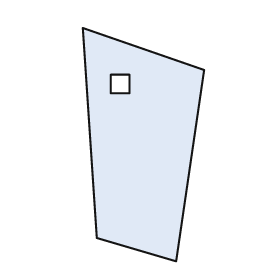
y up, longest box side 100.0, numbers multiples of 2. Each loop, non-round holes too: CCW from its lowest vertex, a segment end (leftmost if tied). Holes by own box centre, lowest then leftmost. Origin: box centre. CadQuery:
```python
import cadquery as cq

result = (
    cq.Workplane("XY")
    .moveTo(14.0, -50.0)
    .lineTo(26.0, 32.0)
    .lineTo(-26.0, 50.0)
    .lineTo(-20.0, -40.0)
    .close()
    .moveTo(-14.0, 22.0)
    .lineTo(-6.0, 22.0)
    .lineTo(-6.0, 30.0)
    .lineTo(-14.0, 30.0)
    .close()
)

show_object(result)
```